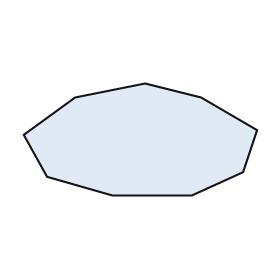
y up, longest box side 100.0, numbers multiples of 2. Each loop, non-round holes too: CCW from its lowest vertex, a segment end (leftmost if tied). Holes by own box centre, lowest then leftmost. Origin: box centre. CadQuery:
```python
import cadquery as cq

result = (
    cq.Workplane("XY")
    .moveTo(-12.0, -24.0)
    .lineTo(22.0, -24.0)
    .lineTo(44.0, -14.0)
    .lineTo(50.0, 4.0)
    .lineTo(26.0, 18.0)
    .lineTo(2.0, 24.0)
    .lineTo(-28.0, 18.0)
    .lineTo(-50.0, 2.0)
    .lineTo(-40.0, -16.0)
    .close()
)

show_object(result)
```